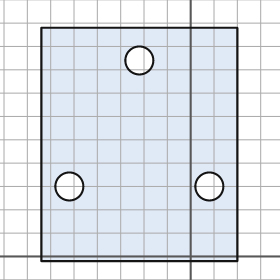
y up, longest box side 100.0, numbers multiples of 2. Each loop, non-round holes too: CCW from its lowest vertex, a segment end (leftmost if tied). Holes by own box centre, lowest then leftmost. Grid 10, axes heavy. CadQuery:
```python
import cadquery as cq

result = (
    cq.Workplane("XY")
    .moveTo(-64.0, -2.0)
    .lineTo(20.0, -2.0)
    .lineTo(20.0, 98.0)
    .lineTo(-64.0, 98.0)
    .close()
    .moveTo(-52.0, 30.0)
    .circle(6.0)
    .moveTo(8.0, 30.0)
    .circle(6.0)
    .moveTo(-22.0, 84.0)
    .circle(6.0)
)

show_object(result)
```